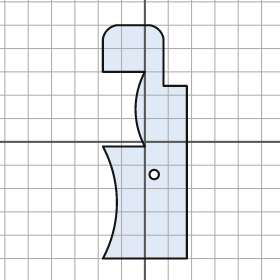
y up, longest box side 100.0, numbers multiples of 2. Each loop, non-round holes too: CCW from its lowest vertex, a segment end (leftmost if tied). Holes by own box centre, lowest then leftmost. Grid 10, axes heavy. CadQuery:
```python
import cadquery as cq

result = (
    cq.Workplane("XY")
    .moveTo(-18.0, -50.0)
    .lineTo(18.0, -50.0)
    .lineTo(18.0, 24.0)
    .lineTo(8.0, 24.0)
    .lineTo(8.0, 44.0)
    .threePointArc((6.0, 48.0), (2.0, 50.0))
    .lineTo(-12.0, 50.0)
    .threePointArc((-16.0, 48.0), (-18.0, 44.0))
    .lineTo(-18.0, 30.0)
    .lineTo(0.0, 30.0)
    .threePointArc((-4.0, 14.0), (0.0, -2.0))
    .lineTo(-18.0, -2.0)
    .threePointArc((-12.0, -26.0), (-18.0, -50.0))
    .close()
    .moveTo(4.0, -14.0)
    .circle(2.0)
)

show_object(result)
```